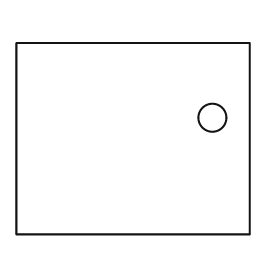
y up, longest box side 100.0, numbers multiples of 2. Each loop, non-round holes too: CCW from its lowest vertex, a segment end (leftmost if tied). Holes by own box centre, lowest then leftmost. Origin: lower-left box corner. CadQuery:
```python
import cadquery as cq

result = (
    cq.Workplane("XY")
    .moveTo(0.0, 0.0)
    .lineTo(100.0, 0.0)
    .lineTo(100.0, 82.0)
    .lineTo(0.0, 82.0)
    .close()
    .moveTo(84.0, 50.0)
    .circle(6.0)
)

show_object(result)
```